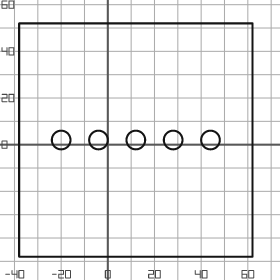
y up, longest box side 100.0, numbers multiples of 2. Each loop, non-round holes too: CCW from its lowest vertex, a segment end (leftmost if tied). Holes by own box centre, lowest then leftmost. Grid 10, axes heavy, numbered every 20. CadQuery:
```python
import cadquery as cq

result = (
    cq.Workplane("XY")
    .moveTo(-38.0, -48.0)
    .lineTo(62.0, -48.0)
    .lineTo(62.0, 52.0)
    .lineTo(-38.0, 52.0)
    .close()
    .moveTo(-20.0, 2.0)
    .circle(4.0)
    .moveTo(-4.0, 2.0)
    .circle(4.0)
    .moveTo(12.0, 2.0)
    .circle(4.0)
    .moveTo(28.0, 2.0)
    .circle(4.0)
    .moveTo(44.0, 2.0)
    .circle(4.0)
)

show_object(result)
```